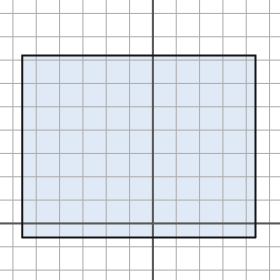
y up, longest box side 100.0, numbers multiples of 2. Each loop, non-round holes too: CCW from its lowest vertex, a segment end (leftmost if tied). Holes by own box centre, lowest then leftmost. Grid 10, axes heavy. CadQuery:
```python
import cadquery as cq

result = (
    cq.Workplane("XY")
    .moveTo(-56.0, -6.0)
    .lineTo(44.0, -6.0)
    .lineTo(44.0, 72.0)
    .lineTo(-56.0, 72.0)
    .close()
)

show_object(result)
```